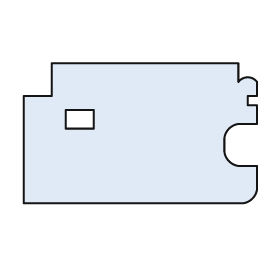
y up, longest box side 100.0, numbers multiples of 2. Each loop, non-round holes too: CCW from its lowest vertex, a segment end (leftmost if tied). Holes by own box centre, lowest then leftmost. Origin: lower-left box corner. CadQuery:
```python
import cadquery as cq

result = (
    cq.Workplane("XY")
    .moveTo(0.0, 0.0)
    .lineTo(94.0, 0.0)
    .threePointArc((98.0, 2.0), (100.0, 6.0))
    .lineTo(100.0, 16.0)
    .lineTo(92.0, 16.0)
    .threePointArc((88.0, 18.0), (86.0, 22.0))
    .lineTo(86.0, 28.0)
    .threePointArc((88.0, 32.0), (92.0, 34.0))
    .lineTo(100.0, 34.0)
    .lineTo(100.0, 42.0)
    .lineTo(96.0, 42.0)
    .lineTo(96.0, 46.0)
    .lineTo(100.0, 46.0)
    .lineTo(100.0, 52.0)
    .threePointArc((96.0, 54.0), (92.0, 52.0))
    .lineTo(92.0, 60.0)
    .lineTo(12.0, 60.0)
    .lineTo(12.0, 46.0)
    .lineTo(0.0, 46.0)
    .close()
    .moveTo(18.0, 32.0)
    .lineTo(30.0, 32.0)
    .lineTo(30.0, 40.0)
    .lineTo(18.0, 40.0)
    .close()
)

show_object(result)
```